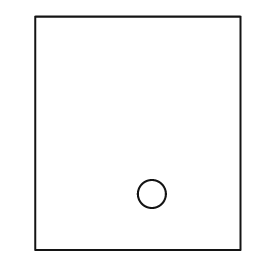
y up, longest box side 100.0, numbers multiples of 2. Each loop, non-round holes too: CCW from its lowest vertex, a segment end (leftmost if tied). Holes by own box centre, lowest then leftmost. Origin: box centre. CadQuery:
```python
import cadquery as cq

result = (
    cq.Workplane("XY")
    .moveTo(-44.0, -50.0)
    .lineTo(44.0, -50.0)
    .lineTo(44.0, 50.0)
    .lineTo(-44.0, 50.0)
    .close()
    .moveTo(6.0, -26.0)
    .circle(6.0)
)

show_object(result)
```